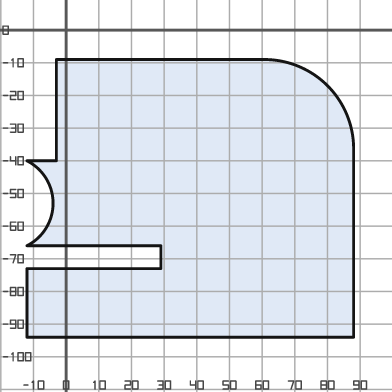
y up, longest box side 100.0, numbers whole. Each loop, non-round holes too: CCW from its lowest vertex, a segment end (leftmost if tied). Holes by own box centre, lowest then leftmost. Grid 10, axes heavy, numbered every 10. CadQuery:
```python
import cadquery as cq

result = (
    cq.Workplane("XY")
    .moveTo(-12.0, -94.0)
    .lineTo(88.0, -94.0)
    .lineTo(88.0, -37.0)
    .threePointArc((80.0, -17.0), (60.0, -9.0))
    .lineTo(-3.0, -9.0)
    .lineTo(-3.0, -40.0)
    .lineTo(-12.0, -40.0)
    .threePointArc((-4.0, -53.0), (-12.0, -66.0))
    .lineTo(29.0, -66.0)
    .lineTo(29.0, -73.0)
    .lineTo(-12.0, -73.0)
    .close()
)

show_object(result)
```